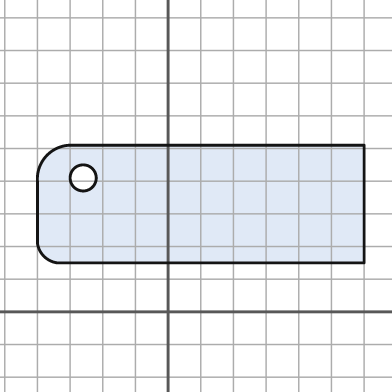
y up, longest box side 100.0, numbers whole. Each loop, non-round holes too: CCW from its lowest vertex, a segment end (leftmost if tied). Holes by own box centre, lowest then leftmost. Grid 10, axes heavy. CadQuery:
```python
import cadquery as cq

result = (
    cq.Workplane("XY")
    .moveTo(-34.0, 15.0)
    .lineTo(60.0, 15.0)
    .lineTo(60.0, 51.0)
    .lineTo(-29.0, 51.0)
    .threePointArc((-37.0, 48.0), (-40.0, 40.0))
    .lineTo(-40.0, 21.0)
    .threePointArc((-38.0, 17.0), (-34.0, 15.0))
    .close()
    .moveTo(-26.0, 41.0)
    .circle(4.0)
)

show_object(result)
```